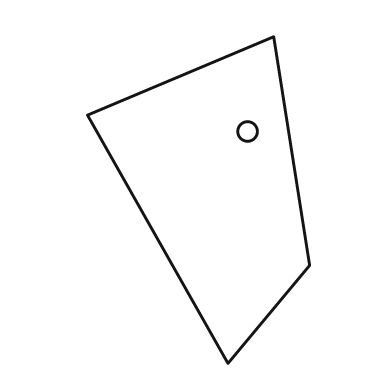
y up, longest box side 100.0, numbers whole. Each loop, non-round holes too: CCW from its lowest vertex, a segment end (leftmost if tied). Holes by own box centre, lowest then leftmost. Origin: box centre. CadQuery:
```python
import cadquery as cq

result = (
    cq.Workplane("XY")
    .moveTo(9.0, -50.0)
    .lineTo(34.0, -20.0)
    .lineTo(23.0, 50.0)
    .lineTo(-34.0, 26.0)
    .close()
    .moveTo(15.0, 21.0)
    .circle(3.0)
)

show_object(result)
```